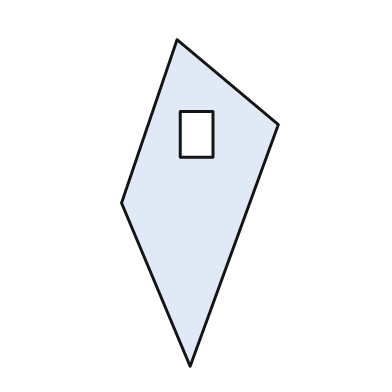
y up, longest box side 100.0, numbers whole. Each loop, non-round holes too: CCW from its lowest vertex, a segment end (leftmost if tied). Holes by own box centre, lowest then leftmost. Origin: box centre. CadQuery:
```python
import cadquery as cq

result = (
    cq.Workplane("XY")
    .moveTo(-3.0, -50.0)
    .lineTo(24.0, 24.0)
    .lineTo(-7.0, 50.0)
    .lineTo(-24.0, 0.0)
    .close()
    .moveTo(-6.0, 14.0)
    .lineTo(4.0, 14.0)
    .lineTo(4.0, 28.0)
    .lineTo(-6.0, 28.0)
    .close()
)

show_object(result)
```